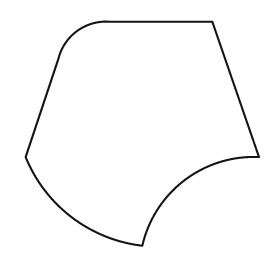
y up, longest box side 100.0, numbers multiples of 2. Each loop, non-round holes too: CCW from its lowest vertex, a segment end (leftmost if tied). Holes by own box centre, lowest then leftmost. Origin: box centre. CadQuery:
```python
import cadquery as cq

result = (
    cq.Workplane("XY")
    .moveTo(0.0, -48.0)
    .threePointArc((18.0, -20.0), (50.0, -10.0))
    .lineTo(30.0, 48.0)
    .lineTo(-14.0, 48.0)
    .threePointArc((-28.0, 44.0), (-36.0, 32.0))
    .lineTo(-50.0, -10.0)
    .threePointArc((-30.0, -36.0), (0.0, -48.0))
    .close()
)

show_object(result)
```